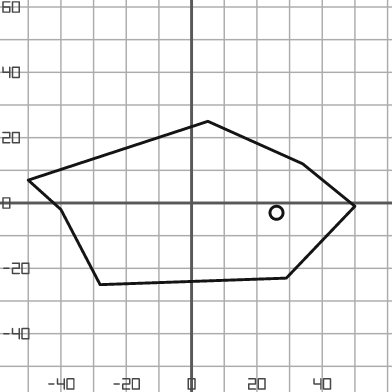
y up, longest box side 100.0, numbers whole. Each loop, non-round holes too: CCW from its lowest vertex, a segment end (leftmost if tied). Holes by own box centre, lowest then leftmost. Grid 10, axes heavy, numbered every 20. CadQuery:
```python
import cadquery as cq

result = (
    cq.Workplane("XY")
    .moveTo(-28.0, -25.0)
    .lineTo(29.0, -23.0)
    .lineTo(50.0, -1.0)
    .lineTo(34.0, 12.0)
    .lineTo(5.0, 25.0)
    .lineTo(-50.0, 7.0)
    .lineTo(-40.0, -2.0)
    .close()
    .moveTo(26.0, -3.0)
    .circle(2.0)
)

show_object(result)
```